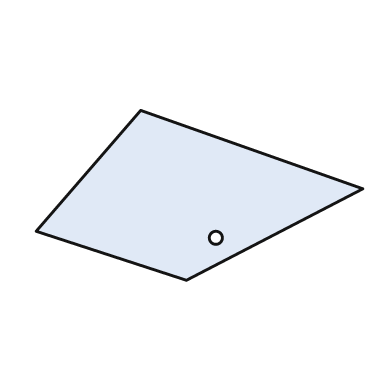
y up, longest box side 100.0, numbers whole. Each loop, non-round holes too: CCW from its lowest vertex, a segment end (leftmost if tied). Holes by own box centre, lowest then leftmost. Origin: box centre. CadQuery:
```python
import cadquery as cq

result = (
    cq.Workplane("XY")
    .moveTo(-4.0, -26.0)
    .lineTo(50.0, 2.0)
    .lineTo(-18.0, 26.0)
    .lineTo(-50.0, -11.0)
    .close()
    .moveTo(5.0, -13.0)
    .circle(2.0)
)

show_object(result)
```